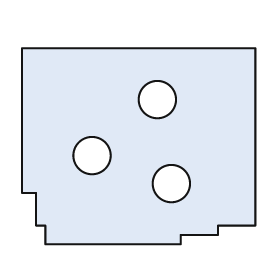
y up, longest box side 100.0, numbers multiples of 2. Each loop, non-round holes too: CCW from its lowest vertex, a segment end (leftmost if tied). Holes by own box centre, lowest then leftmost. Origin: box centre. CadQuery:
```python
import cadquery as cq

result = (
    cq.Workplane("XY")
    .moveTo(-40.0, -42.0)
    .lineTo(18.0, -42.0)
    .lineTo(18.0, -38.0)
    .lineTo(34.0, -38.0)
    .lineTo(34.0, -34.0)
    .lineTo(50.0, -34.0)
    .lineTo(50.0, 42.0)
    .lineTo(-50.0, 42.0)
    .lineTo(-50.0, -20.0)
    .lineTo(-44.0, -20.0)
    .lineTo(-44.0, -34.0)
    .lineTo(-40.0, -34.0)
    .close()
    .moveTo(14.0, -16.0)
    .circle(8.0)
    .moveTo(-20.0, -4.0)
    .circle(8.0)
    .moveTo(8.0, 20.0)
    .circle(8.0)
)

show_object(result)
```